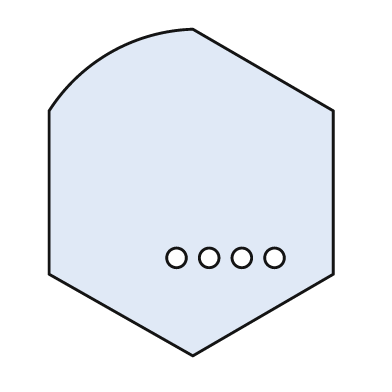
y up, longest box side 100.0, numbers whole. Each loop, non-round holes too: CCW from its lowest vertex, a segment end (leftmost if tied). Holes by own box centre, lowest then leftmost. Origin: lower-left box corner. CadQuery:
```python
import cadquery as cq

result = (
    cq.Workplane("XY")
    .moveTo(44.0, 0.0)
    .lineTo(87.0, 25.0)
    .lineTo(87.0, 75.0)
    .lineTo(44.0, 100.0)
    .threePointArc((19.0, 93.0), (0.0, 75.0))
    .lineTo(0.0, 25.0)
    .close()
    .moveTo(39.0, 30.0)
    .circle(3.0)
    .moveTo(49.0, 30.0)
    .circle(3.0)
    .moveTo(59.0, 30.0)
    .circle(3.0)
    .moveTo(69.0, 30.0)
    .circle(3.0)
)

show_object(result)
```